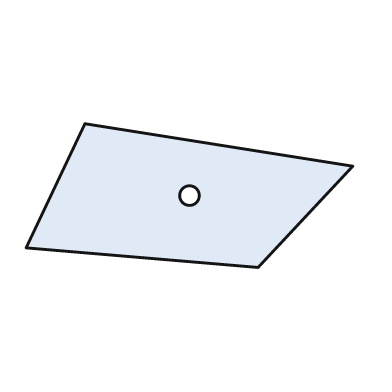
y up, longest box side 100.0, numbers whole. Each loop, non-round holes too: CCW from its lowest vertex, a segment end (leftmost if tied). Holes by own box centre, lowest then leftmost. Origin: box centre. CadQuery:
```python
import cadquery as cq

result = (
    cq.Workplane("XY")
    .moveTo(21.0, -22.0)
    .lineTo(50.0, 9.0)
    .lineTo(-32.0, 22.0)
    .lineTo(-50.0, -16.0)
    .close()
    .moveTo(0.0, 0.0)
    .circle(3.0)
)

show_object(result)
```